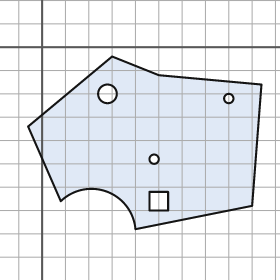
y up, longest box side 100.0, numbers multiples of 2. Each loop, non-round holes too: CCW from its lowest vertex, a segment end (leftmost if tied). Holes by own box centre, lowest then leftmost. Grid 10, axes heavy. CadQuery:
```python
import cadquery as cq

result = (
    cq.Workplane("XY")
    .moveTo(40.0, -78.0)
    .lineTo(90.0, -68.0)
    .lineTo(94.0, -16.0)
    .lineTo(50.0, -12.0)
    .lineTo(30.0, -4.0)
    .lineTo(-6.0, -34.0)
    .lineTo(8.0, -66.0)
    .threePointArc((28.0, -62.0), (40.0, -78.0))
    .close()
    .moveTo(46.0, -70.0)
    .lineTo(54.0, -70.0)
    .lineTo(54.0, -62.0)
    .lineTo(46.0, -62.0)
    .close()
    .moveTo(48.0, -48.0)
    .circle(2.0)
    .moveTo(80.0, -22.0)
    .circle(2.0)
    .moveTo(28.0, -20.0)
    .circle(4.0)
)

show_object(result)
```